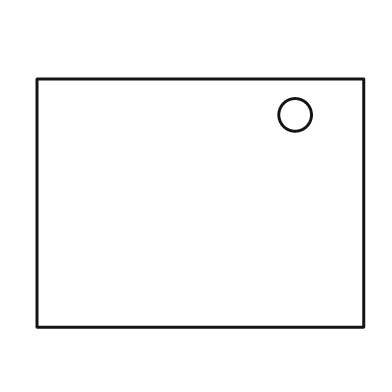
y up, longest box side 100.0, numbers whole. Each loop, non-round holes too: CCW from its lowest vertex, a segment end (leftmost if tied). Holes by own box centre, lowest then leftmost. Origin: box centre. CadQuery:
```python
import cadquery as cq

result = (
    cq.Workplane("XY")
    .moveTo(-50.0, -38.0)
    .lineTo(50.0, -38.0)
    .lineTo(50.0, 38.0)
    .lineTo(-50.0, 38.0)
    .close()
    .moveTo(29.0, 27.0)
    .circle(5.0)
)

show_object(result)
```